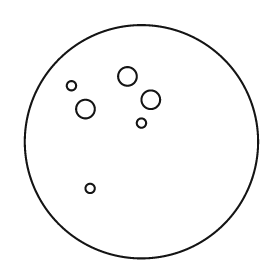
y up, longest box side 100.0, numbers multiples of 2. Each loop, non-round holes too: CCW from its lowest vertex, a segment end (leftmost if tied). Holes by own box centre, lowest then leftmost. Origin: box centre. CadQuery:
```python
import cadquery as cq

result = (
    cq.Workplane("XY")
    .moveTo(0.0, 0.0)
    .circle(50.0)
    .moveTo(-22.0, -20.0)
    .circle(2.0)
    .moveTo(0.0, 8.0)
    .circle(2.0)
    .moveTo(-24.0, 14.0)
    .circle(4.0)
    .moveTo(4.0, 18.0)
    .circle(4.0)
    .moveTo(-30.0, 24.0)
    .circle(2.0)
    .moveTo(-6.0, 28.0)
    .circle(4.0)
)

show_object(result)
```